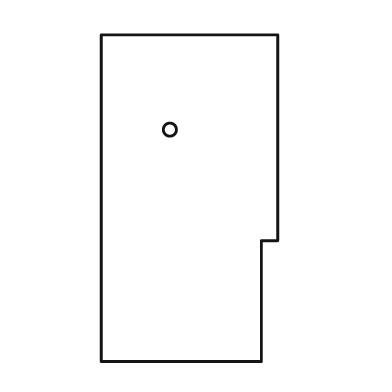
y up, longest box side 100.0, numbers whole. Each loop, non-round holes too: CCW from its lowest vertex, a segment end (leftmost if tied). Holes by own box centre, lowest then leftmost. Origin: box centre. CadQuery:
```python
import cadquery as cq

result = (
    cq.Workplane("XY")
    .moveTo(-27.0, -50.0)
    .lineTo(22.0, -50.0)
    .lineTo(22.0, -13.0)
    .lineTo(27.0, -13.0)
    .lineTo(27.0, 50.0)
    .lineTo(-27.0, 50.0)
    .close()
    .moveTo(-6.0, 21.0)
    .circle(2.0)
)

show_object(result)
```